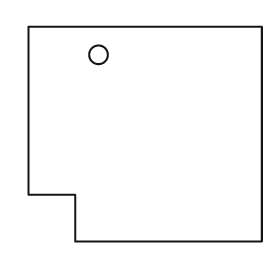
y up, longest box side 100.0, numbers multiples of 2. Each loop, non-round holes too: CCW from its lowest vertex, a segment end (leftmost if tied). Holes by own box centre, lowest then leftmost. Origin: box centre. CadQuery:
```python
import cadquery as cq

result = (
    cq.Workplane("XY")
    .moveTo(-30.0, -46.0)
    .lineTo(50.0, -46.0)
    .lineTo(50.0, 46.0)
    .lineTo(-50.0, 46.0)
    .lineTo(-50.0, -26.0)
    .lineTo(-30.0, -26.0)
    .close()
    .moveTo(-20.0, 34.0)
    .circle(4.0)
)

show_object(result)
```